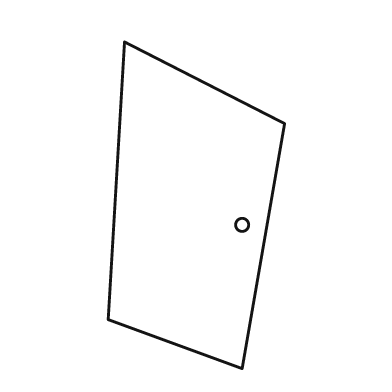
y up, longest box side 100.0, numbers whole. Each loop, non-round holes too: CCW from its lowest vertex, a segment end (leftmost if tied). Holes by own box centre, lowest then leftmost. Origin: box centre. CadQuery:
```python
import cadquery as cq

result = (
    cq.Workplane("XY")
    .moveTo(14.0, -50.0)
    .lineTo(27.0, 25.0)
    .lineTo(-22.0, 50.0)
    .lineTo(-27.0, -35.0)
    .close()
    .moveTo(14.0, -6.0)
    .circle(2.0)
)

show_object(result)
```